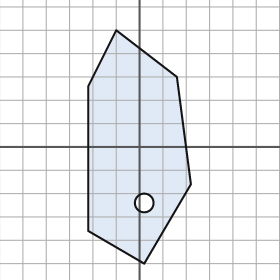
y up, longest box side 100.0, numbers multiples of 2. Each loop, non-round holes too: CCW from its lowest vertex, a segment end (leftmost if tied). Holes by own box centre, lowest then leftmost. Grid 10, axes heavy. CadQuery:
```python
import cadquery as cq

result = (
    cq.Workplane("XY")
    .moveTo(2.0, -50.0)
    .lineTo(22.0, -16.0)
    .lineTo(16.0, 30.0)
    .lineTo(-10.0, 50.0)
    .lineTo(-22.0, 26.0)
    .lineTo(-22.0, -36.0)
    .close()
    .moveTo(2.0, -24.0)
    .circle(4.0)
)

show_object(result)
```